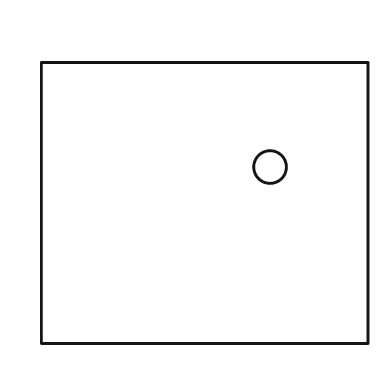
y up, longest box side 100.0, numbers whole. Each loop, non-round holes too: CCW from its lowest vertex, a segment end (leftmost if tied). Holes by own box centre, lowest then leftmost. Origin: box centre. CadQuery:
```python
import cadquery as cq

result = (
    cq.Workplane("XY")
    .moveTo(-50.0, -43.0)
    .lineTo(50.0, -43.0)
    .lineTo(50.0, 43.0)
    .lineTo(-50.0, 43.0)
    .close()
    .moveTo(20.0, 11.0)
    .circle(5.0)
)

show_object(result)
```